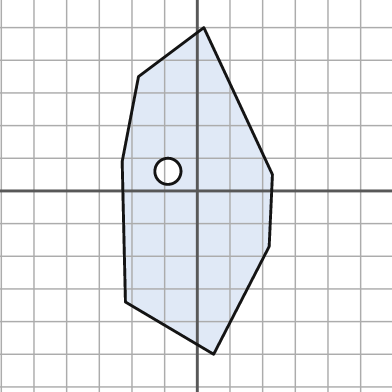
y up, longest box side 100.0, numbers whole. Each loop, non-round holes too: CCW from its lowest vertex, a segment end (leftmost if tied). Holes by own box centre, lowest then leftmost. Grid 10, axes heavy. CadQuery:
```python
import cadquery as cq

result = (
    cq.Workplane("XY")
    .moveTo(5.0, -50.0)
    .lineTo(22.0, -17.0)
    .lineTo(23.0, 5.0)
    .lineTo(2.0, 50.0)
    .lineTo(-18.0, 35.0)
    .lineTo(-23.0, 9.0)
    .lineTo(-22.0, -34.0)
    .close()
    .moveTo(-9.0, 6.0)
    .circle(4.0)
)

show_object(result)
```